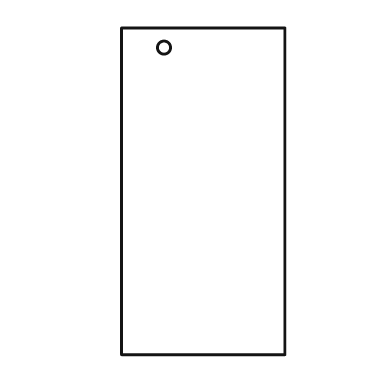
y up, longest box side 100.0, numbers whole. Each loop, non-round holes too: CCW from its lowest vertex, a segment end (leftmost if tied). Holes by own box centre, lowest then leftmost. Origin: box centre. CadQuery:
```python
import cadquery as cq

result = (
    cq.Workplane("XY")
    .moveTo(-25.0, -50.0)
    .lineTo(25.0, -50.0)
    .lineTo(25.0, 50.0)
    .lineTo(-25.0, 50.0)
    .close()
    .moveTo(-12.0, 44.0)
    .circle(2.0)
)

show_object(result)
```